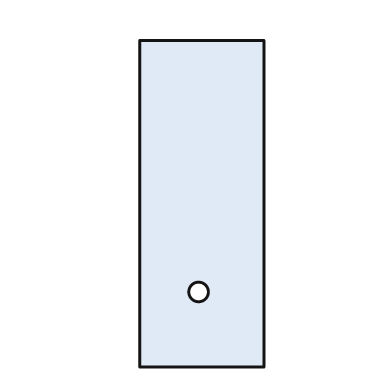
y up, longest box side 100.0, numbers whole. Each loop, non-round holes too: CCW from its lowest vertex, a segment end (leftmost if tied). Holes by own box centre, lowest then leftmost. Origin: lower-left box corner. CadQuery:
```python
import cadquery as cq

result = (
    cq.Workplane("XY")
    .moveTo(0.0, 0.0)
    .lineTo(38.0, 0.0)
    .lineTo(38.0, 100.0)
    .lineTo(0.0, 100.0)
    .close()
    .moveTo(18.0, 23.0)
    .circle(3.0)
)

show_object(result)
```